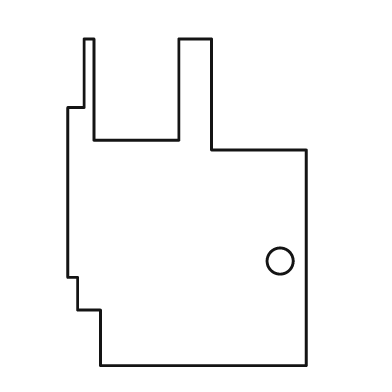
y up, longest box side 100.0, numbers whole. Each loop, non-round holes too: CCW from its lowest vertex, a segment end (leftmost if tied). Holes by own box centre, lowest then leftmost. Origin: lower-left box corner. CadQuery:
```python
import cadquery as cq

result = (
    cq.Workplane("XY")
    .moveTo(10.0, 0.0)
    .lineTo(73.0, 0.0)
    .lineTo(73.0, 66.0)
    .lineTo(44.0, 66.0)
    .lineTo(44.0, 100.0)
    .lineTo(34.0, 100.0)
    .lineTo(34.0, 69.0)
    .lineTo(8.0, 69.0)
    .lineTo(8.0, 100.0)
    .lineTo(5.0, 100.0)
    .lineTo(5.0, 79.0)
    .lineTo(0.0, 79.0)
    .lineTo(0.0, 27.0)
    .lineTo(3.0, 27.0)
    .lineTo(3.0, 17.0)
    .lineTo(10.0, 17.0)
    .close()
    .moveTo(65.0, 32.0)
    .circle(4.0)
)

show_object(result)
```